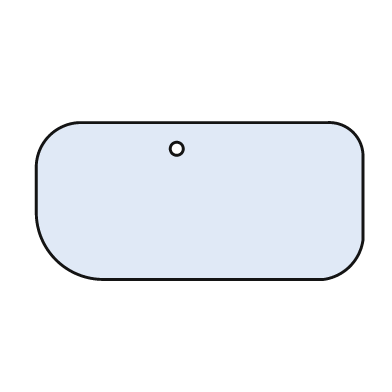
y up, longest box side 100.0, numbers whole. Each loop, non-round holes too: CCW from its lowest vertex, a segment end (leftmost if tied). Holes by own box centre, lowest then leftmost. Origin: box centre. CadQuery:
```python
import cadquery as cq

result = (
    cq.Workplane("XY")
    .moveTo(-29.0, -24.0)
    .lineTo(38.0, -24.0)
    .threePointArc((46.0, -20.0), (50.0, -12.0))
    .lineTo(50.0, 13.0)
    .threePointArc((47.0, 21.0), (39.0, 24.0))
    .lineTo(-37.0, 24.0)
    .threePointArc((-46.0, 20.0), (-50.0, 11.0))
    .lineTo(-50.0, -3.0)
    .threePointArc((-44.0, -18.0), (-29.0, -24.0))
    .close()
    .moveTo(-7.0, 16.0)
    .circle(2.0)
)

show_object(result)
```